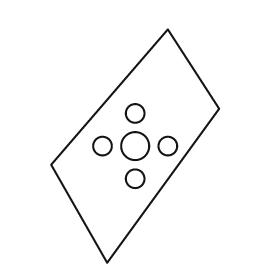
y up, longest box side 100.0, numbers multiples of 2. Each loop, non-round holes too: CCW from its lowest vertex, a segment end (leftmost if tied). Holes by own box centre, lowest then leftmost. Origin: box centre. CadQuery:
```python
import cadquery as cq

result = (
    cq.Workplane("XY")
    .moveTo(-12.0, -50.0)
    .lineTo(36.0, 16.0)
    .lineTo(14.0, 50.0)
    .lineTo(-36.0, -8.0)
    .close()
    .moveTo(0.0, -14.0)
    .circle(4.0)
    .moveTo(-14.0, 0.0)
    .circle(4.0)
    .moveTo(0.0, 0.0)
    .circle(6.0)
    .moveTo(14.0, 0.0)
    .circle(4.0)
    .moveTo(0.0, 14.0)
    .circle(4.0)
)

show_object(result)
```